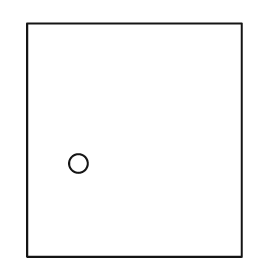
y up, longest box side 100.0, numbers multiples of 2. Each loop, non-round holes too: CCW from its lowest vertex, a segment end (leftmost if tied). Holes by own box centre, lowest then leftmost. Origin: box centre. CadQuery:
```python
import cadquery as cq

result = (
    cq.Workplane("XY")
    .moveTo(-46.0, -50.0)
    .lineTo(46.0, -50.0)
    .lineTo(46.0, 50.0)
    .lineTo(-46.0, 50.0)
    .close()
    .moveTo(-24.0, -10.0)
    .circle(4.0)
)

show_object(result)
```